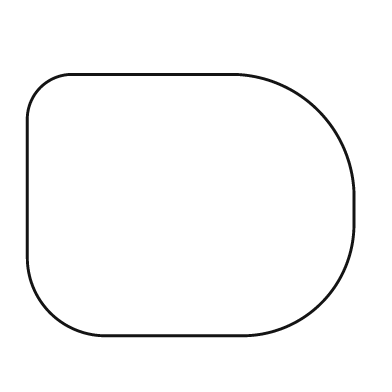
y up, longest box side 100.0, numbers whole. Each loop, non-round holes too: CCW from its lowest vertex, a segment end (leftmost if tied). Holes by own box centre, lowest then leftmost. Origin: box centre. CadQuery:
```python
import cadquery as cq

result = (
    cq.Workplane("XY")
    .moveTo(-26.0, -40.0)
    .lineTo(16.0, -40.0)
    .threePointArc((40.0, -30.0), (50.0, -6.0))
    .lineTo(50.0, 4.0)
    .threePointArc((39.0, 29.0), (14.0, 40.0))
    .lineTo(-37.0, 40.0)
    .threePointArc((-46.0, 36.0), (-50.0, 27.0))
    .lineTo(-50.0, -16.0)
    .threePointArc((-43.0, -33.0), (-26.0, -40.0))
    .close()
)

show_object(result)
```